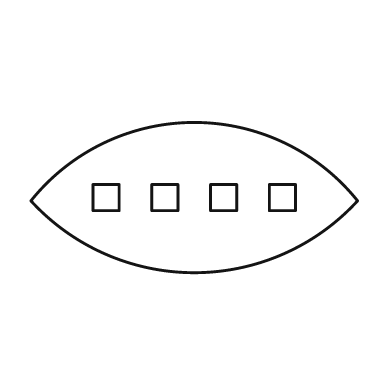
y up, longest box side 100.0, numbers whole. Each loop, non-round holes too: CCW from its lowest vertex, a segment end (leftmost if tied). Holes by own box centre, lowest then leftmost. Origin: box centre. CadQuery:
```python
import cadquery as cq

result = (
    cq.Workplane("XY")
    .moveTo(-50.0, -1.0)
    .threePointArc((0.0, -23.0), (50.0, -1.0))
    .threePointArc((0.0, 23.0), (-50.0, -1.0))
    .close()
    .moveTo(-31.0, -4.0)
    .lineTo(-23.0, -4.0)
    .lineTo(-23.0, 4.0)
    .lineTo(-31.0, 4.0)
    .close()
    .moveTo(-13.0, -4.0)
    .lineTo(-5.0, -4.0)
    .lineTo(-5.0, 4.0)
    .lineTo(-13.0, 4.0)
    .close()
    .moveTo(5.0, -4.0)
    .lineTo(13.0, -4.0)
    .lineTo(13.0, 4.0)
    .lineTo(5.0, 4.0)
    .close()
    .moveTo(23.0, -4.0)
    .lineTo(31.0, -4.0)
    .lineTo(31.0, 4.0)
    .lineTo(23.0, 4.0)
    .close()
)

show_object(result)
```